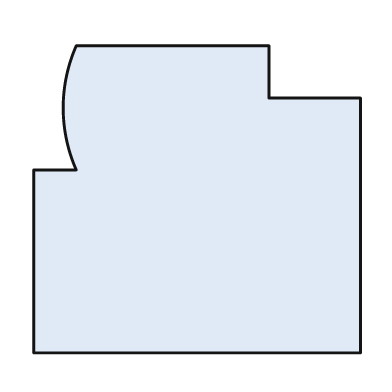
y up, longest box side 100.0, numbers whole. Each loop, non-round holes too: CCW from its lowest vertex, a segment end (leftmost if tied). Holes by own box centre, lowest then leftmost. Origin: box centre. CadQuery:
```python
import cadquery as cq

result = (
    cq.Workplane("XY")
    .moveTo(-50.0, -47.0)
    .lineTo(50.0, -47.0)
    .lineTo(50.0, 31.0)
    .lineTo(22.0, 31.0)
    .lineTo(22.0, 47.0)
    .lineTo(-37.0, 47.0)
    .threePointArc((-41.0, 28.0), (-37.0, 9.0))
    .lineTo(-50.0, 9.0)
    .close()
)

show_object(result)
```